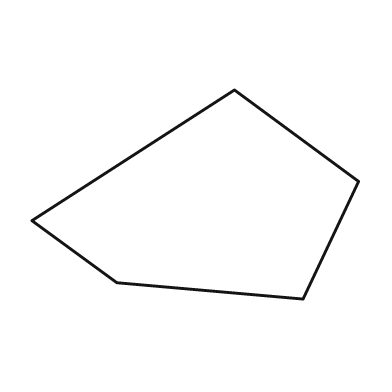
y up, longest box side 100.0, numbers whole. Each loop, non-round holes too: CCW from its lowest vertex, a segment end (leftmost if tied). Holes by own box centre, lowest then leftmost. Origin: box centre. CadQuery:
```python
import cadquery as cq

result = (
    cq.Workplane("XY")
    .moveTo(33.0, -32.0)
    .lineTo(50.0, 4.0)
    .lineTo(12.0, 32.0)
    .lineTo(-50.0, -8.0)
    .lineTo(-24.0, -27.0)
    .close()
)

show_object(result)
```